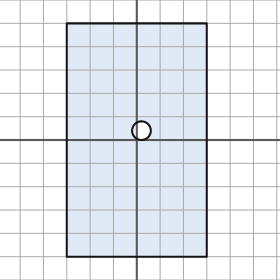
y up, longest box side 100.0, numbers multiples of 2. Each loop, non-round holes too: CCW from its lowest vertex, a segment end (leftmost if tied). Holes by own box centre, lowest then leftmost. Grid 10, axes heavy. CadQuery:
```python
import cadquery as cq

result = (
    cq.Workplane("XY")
    .moveTo(-30.0, -50.0)
    .lineTo(30.0, -50.0)
    .lineTo(30.0, 50.0)
    .lineTo(-30.0, 50.0)
    .close()
    .moveTo(2.0, 4.0)
    .circle(4.0)
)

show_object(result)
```